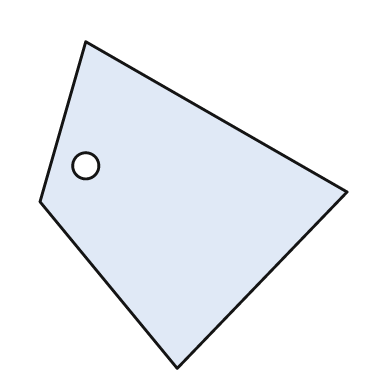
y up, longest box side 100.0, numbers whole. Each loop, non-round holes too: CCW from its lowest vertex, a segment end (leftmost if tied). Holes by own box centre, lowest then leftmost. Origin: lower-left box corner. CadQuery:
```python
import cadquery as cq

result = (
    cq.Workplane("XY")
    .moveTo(42.0, 0.0)
    .lineTo(94.0, 54.0)
    .lineTo(14.0, 100.0)
    .lineTo(0.0, 51.0)
    .close()
    .moveTo(14.0, 62.0)
    .circle(4.0)
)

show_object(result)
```